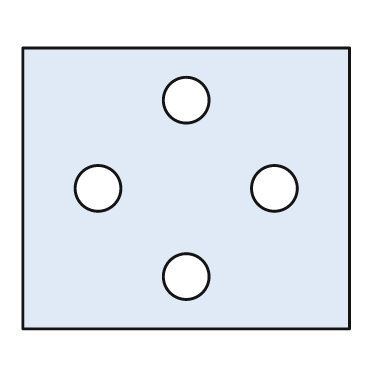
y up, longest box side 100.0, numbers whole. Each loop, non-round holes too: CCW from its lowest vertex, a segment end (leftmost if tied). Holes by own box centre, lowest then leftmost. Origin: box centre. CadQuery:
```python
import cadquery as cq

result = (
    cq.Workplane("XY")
    .moveTo(-50.0, -43.0)
    .lineTo(50.0, -43.0)
    .lineTo(50.0, 43.0)
    .lineTo(-50.0, 43.0)
    .close()
    .moveTo(0.0, -27.0)
    .circle(7.0)
    .moveTo(-27.0, 0.0)
    .circle(7.0)
    .moveTo(27.0, 0.0)
    .circle(7.0)
    .moveTo(0.0, 27.0)
    .circle(7.0)
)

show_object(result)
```